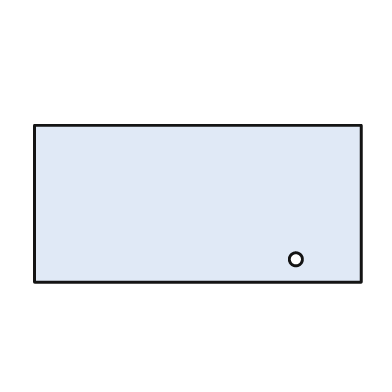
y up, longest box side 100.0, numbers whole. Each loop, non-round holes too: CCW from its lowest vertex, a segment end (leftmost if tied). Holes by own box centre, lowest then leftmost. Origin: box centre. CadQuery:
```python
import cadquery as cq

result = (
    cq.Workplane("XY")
    .moveTo(-50.0, -24.0)
    .lineTo(50.0, -24.0)
    .lineTo(50.0, 24.0)
    .lineTo(-50.0, 24.0)
    .close()
    .moveTo(30.0, -17.0)
    .circle(2.0)
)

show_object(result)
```